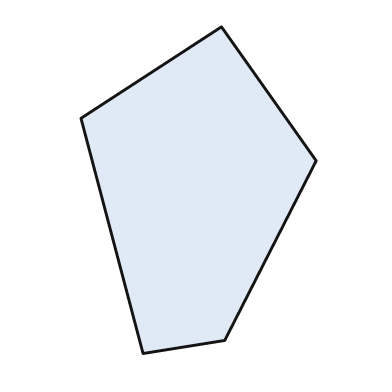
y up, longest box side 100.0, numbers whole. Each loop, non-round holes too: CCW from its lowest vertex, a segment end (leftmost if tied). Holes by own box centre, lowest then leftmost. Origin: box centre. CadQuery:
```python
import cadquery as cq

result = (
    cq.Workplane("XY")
    .moveTo(-17.0, -50.0)
    .lineTo(8.0, -46.0)
    .lineTo(36.0, 9.0)
    .lineTo(7.0, 50.0)
    .lineTo(-36.0, 22.0)
    .close()
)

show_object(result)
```